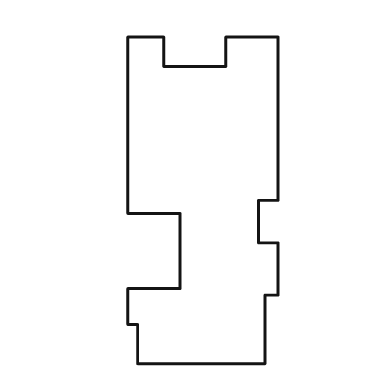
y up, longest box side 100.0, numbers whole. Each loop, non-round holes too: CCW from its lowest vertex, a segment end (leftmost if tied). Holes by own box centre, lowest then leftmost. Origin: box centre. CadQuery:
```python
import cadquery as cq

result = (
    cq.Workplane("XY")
    .moveTo(-20.0, -50.0)
    .lineTo(19.0, -50.0)
    .lineTo(19.0, -29.0)
    .lineTo(23.0, -29.0)
    .lineTo(23.0, -13.0)
    .lineTo(17.0, -13.0)
    .lineTo(17.0, 0.0)
    .lineTo(23.0, 0.0)
    .lineTo(23.0, 50.0)
    .lineTo(7.0, 50.0)
    .lineTo(7.0, 41.0)
    .lineTo(-12.0, 41.0)
    .lineTo(-12.0, 50.0)
    .lineTo(-23.0, 50.0)
    .lineTo(-23.0, -4.0)
    .lineTo(-7.0, -4.0)
    .lineTo(-7.0, -27.0)
    .lineTo(-23.0, -27.0)
    .lineTo(-23.0, -38.0)
    .lineTo(-20.0, -38.0)
    .close()
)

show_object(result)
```